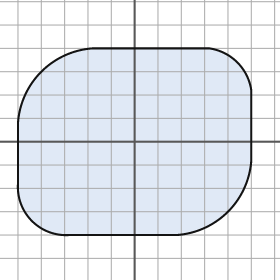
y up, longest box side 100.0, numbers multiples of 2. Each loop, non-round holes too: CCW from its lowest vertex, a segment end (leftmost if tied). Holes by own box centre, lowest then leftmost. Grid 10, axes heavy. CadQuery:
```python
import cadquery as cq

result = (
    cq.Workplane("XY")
    .moveTo(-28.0, -40.0)
    .lineTo(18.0, -40.0)
    .threePointArc((40.0, -30.0), (50.0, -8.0))
    .lineTo(50.0, 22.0)
    .threePointArc((44.0, 34.0), (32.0, 40.0))
    .lineTo(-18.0, 40.0)
    .threePointArc((-40.0, 30.0), (-50.0, 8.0))
    .lineTo(-50.0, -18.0)
    .threePointArc((-44.0, -34.0), (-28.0, -40.0))
    .close()
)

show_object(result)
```